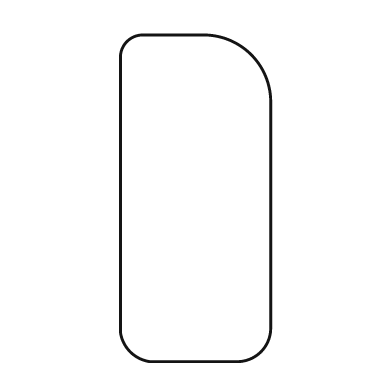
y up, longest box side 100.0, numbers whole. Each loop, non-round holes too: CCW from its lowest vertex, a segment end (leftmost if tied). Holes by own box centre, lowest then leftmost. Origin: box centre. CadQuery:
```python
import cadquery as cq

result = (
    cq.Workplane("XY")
    .moveTo(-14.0, -50.0)
    .lineTo(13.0, -50.0)
    .threePointArc((20.0, -47.0), (23.0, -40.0))
    .lineTo(23.0, 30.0)
    .threePointArc((17.0, 44.0), (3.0, 50.0))
    .lineTo(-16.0, 50.0)
    .threePointArc((-21.0, 48.0), (-23.0, 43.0))
    .lineTo(-23.0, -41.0)
    .threePointArc((-20.0, -47.0), (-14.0, -50.0))
    .close()
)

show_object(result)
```